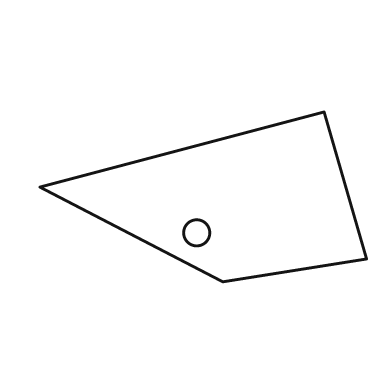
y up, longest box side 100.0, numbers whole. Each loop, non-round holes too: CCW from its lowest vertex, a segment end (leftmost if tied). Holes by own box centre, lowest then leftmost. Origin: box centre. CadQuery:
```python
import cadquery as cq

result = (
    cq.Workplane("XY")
    .moveTo(6.0, -26.0)
    .lineTo(50.0, -19.0)
    .lineTo(37.0, 26.0)
    .lineTo(-50.0, 3.0)
    .close()
    .moveTo(-2.0, -11.0)
    .circle(4.0)
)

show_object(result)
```